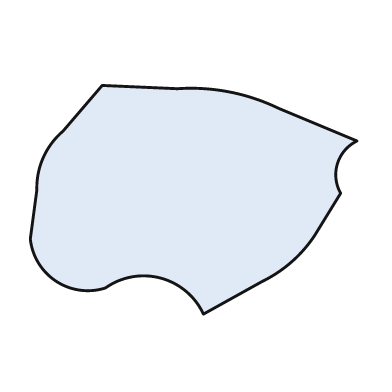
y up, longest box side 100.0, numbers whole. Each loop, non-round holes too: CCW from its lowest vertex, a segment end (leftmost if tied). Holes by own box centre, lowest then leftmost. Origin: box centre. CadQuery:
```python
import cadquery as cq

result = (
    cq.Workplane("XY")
    .moveTo(3.0, -35.0)
    .lineTo(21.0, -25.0)
    .threePointArc((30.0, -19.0), (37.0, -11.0))
    .lineTo(45.0, 2.0)
    .threePointArc((44.0, 11.0), (50.0, 18.0))
    .lineTo(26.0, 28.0)
    .threePointArc((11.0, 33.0), (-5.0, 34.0))
    .lineTo(-28.0, 35.0)
    .lineTo(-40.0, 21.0)
    .threePointArc((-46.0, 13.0), (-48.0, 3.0))
    .lineTo(-50.0, -12.0)
    .threePointArc((-42.0, -25.0), (-27.0, -27.0))
    .threePointArc((-10.0, -24.0), (3.0, -35.0))
    .close()
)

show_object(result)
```